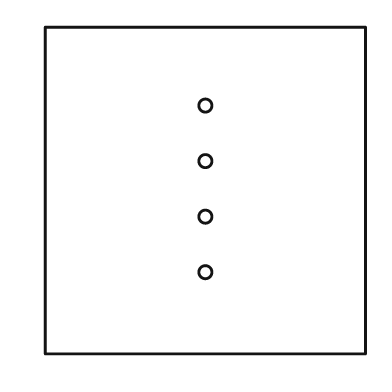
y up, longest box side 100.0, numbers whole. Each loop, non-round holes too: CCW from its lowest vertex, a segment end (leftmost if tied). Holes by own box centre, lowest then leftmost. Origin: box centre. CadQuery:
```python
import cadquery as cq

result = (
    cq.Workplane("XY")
    .moveTo(-49.0, -50.0)
    .lineTo(49.0, -50.0)
    .lineTo(49.0, 50.0)
    .lineTo(-49.0, 50.0)
    .close()
    .moveTo(0.0, -25.0)
    .circle(2.0)
    .moveTo(0.0, -8.0)
    .circle(2.0)
    .moveTo(0.0, 9.0)
    .circle(2.0)
    .moveTo(0.0, 26.0)
    .circle(2.0)
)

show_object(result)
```